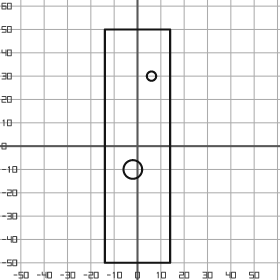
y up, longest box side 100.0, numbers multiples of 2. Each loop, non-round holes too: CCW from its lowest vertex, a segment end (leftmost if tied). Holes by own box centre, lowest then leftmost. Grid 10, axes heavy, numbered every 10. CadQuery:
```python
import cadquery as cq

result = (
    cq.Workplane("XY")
    .moveTo(-14.0, -50.0)
    .lineTo(14.0, -50.0)
    .lineTo(14.0, 50.0)
    .lineTo(-14.0, 50.0)
    .close()
    .moveTo(-2.0, -10.0)
    .circle(4.0)
    .moveTo(6.0, 30.0)
    .circle(2.0)
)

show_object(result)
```